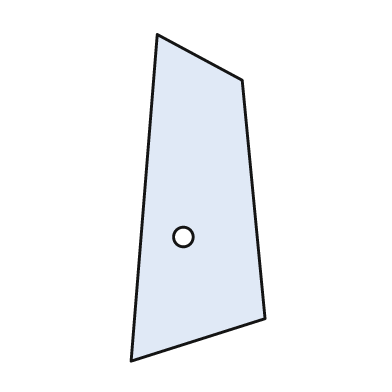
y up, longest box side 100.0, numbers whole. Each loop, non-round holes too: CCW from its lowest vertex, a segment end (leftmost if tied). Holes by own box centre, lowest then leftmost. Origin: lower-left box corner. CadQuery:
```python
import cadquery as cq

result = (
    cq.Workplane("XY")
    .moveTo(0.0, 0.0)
    .lineTo(41.0, 13.0)
    .lineTo(34.0, 86.0)
    .lineTo(8.0, 100.0)
    .close()
    .moveTo(16.0, 38.0)
    .circle(3.0)
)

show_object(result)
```